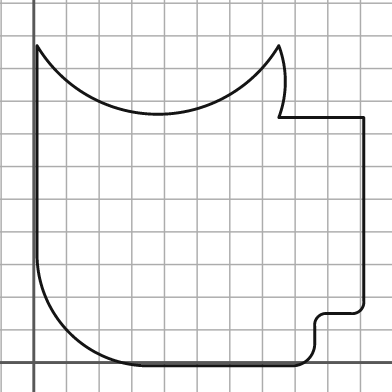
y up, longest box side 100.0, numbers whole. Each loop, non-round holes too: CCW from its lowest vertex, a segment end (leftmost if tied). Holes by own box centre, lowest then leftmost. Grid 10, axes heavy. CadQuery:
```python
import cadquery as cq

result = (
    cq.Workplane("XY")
    .moveTo(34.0, -1.0)
    .lineTo(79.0, -1.0)
    .threePointArc((84.0, 1.0), (86.0, 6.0))
    .lineTo(86.0, 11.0)
    .threePointArc((87.0, 14.0), (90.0, 15.0))
    .lineTo(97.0, 15.0)
    .threePointArc((100.0, 16.0), (101.0, 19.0))
    .lineTo(101.0, 75.0)
    .lineTo(75.0, 75.0)
    .threePointArc((77.0, 86.0), (75.0, 97.0))
    .threePointArc((38.0, 76.0), (1.0, 97.0))
    .lineTo(1.0, 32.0)
    .threePointArc((11.0, 9.0), (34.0, -1.0))
    .close()
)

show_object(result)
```